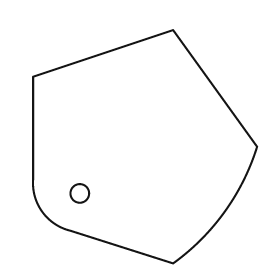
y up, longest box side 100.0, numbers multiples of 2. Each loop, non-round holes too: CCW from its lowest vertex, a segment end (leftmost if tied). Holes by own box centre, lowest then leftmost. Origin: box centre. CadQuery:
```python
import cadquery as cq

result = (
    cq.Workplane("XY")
    .moveTo(12.0, -50.0)
    .threePointArc((34.0, -28.0), (48.0, 0.0))
    .lineTo(12.0, 50.0)
    .lineTo(-48.0, 30.0)
    .lineTo(-48.0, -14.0)
    .threePointArc((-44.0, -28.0), (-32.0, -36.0))
    .close()
    .moveTo(-28.0, -20.0)
    .circle(4.0)
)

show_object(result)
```